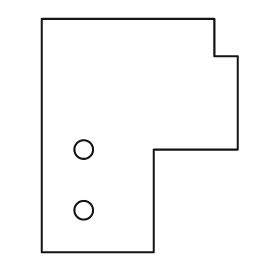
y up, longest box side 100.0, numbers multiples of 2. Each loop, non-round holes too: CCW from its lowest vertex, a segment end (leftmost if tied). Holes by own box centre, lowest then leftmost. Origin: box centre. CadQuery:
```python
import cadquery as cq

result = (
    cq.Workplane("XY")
    .moveTo(-42.0, -50.0)
    .lineTo(6.0, -50.0)
    .lineTo(6.0, -6.0)
    .lineTo(42.0, -6.0)
    .lineTo(42.0, 34.0)
    .lineTo(32.0, 34.0)
    .lineTo(32.0, 50.0)
    .lineTo(-42.0, 50.0)
    .close()
    .moveTo(-24.0, -32.0)
    .circle(4.0)
    .moveTo(-24.0, -6.0)
    .circle(4.0)
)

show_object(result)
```